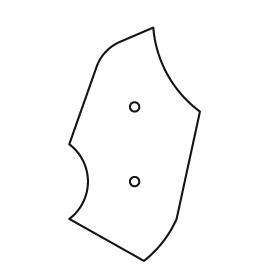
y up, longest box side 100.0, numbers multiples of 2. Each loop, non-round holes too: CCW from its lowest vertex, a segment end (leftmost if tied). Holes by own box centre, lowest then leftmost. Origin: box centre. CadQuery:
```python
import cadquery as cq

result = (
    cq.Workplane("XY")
    .moveTo(4.0, -50.0)
    .threePointArc((12.0, -42.0), (18.0, -32.0))
    .lineTo(28.0, 14.0)
    .threePointArc((14.0, 30.0), (8.0, 50.0))
    .lineTo(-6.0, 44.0)
    .threePointArc((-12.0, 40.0), (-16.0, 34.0))
    .lineTo(-28.0, 0.0)
    .threePointArc((-20.0, -16.0), (-28.0, -32.0))
    .close()
    .moveTo(0.0, -16.0)
    .circle(2.0)
    .moveTo(0.0, 16.0)
    .circle(2.0)
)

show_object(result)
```